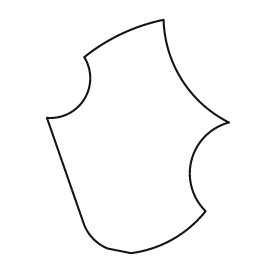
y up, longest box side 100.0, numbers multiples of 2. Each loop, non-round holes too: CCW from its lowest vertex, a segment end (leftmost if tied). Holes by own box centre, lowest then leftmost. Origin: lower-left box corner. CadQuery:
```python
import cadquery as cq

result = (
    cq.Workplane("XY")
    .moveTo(36.0, 0.0)
    .threePointArc((54.0, 6.0), (68.0, 18.0))
    .threePointArc((62.0, 40.0), (78.0, 56.0))
    .threePointArc((58.0, 74.0), (50.0, 100.0))
    .threePointArc((32.0, 94.0), (16.0, 84.0))
    .threePointArc((16.0, 66.0), (0.0, 58.0))
    .lineTo(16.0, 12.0)
    .threePointArc((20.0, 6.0), (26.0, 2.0))
    .close()
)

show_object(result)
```